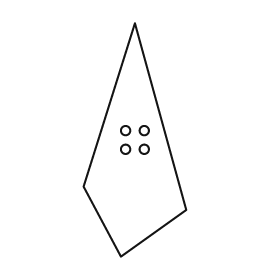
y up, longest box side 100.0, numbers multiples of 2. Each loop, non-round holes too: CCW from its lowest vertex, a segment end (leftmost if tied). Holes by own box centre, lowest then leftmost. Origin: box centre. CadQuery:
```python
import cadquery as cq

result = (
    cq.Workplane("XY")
    .moveTo(-6.0, -50.0)
    .lineTo(22.0, -30.0)
    .lineTo(0.0, 50.0)
    .lineTo(-22.0, -20.0)
    .close()
    .moveTo(-4.0, -4.0)
    .circle(2.0)
    .moveTo(4.0, -4.0)
    .circle(2.0)
    .moveTo(-4.0, 4.0)
    .circle(2.0)
    .moveTo(4.0, 4.0)
    .circle(2.0)
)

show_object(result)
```